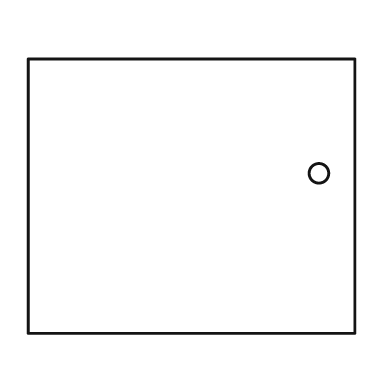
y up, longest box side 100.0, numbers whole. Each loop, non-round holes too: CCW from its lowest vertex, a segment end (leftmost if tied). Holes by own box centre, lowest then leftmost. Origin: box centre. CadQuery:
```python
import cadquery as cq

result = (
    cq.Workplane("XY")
    .moveTo(-50.0, -42.0)
    .lineTo(50.0, -42.0)
    .lineTo(50.0, 42.0)
    .lineTo(-50.0, 42.0)
    .close()
    .moveTo(39.0, 7.0)
    .circle(3.0)
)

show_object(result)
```